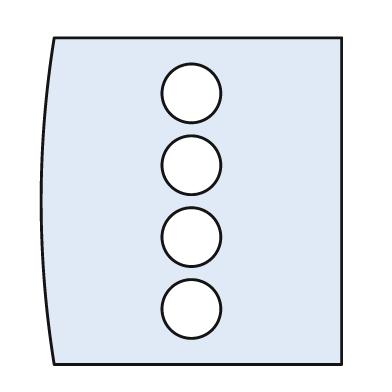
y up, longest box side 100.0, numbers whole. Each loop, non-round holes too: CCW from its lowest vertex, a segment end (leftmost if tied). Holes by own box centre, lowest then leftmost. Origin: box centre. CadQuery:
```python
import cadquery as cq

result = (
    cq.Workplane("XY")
    .moveTo(-42.0, -50.0)
    .lineTo(46.0, -50.0)
    .lineTo(46.0, 50.0)
    .lineTo(-42.0, 50.0)
    .threePointArc((-46.0, 0.0), (-42.0, -50.0))
    .close()
    .moveTo(0.0, -33.0)
    .circle(9.0)
    .moveTo(0.0, -11.0)
    .circle(9.0)
    .moveTo(0.0, 11.0)
    .circle(9.0)
    .moveTo(0.0, 33.0)
    .circle(9.0)
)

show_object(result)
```